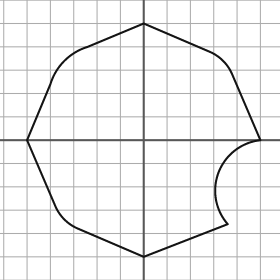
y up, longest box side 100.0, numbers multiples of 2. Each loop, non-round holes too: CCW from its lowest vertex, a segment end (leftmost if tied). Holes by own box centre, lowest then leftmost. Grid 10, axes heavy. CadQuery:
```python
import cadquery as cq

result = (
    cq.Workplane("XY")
    .moveTo(0.0, -50.0)
    .lineTo(36.0, -36.0)
    .threePointArc((32.0, -14.0), (50.0, 0.0))
    .lineTo(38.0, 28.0)
    .threePointArc((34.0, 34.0), (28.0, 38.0))
    .lineTo(0.0, 50.0)
    .lineTo(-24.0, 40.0)
    .threePointArc((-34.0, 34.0), (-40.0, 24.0))
    .lineTo(-50.0, 0.0)
    .lineTo(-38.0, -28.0)
    .threePointArc((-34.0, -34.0), (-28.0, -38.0))
    .close()
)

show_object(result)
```